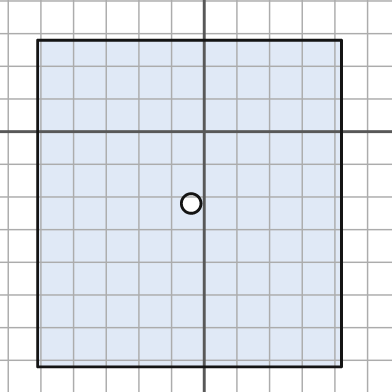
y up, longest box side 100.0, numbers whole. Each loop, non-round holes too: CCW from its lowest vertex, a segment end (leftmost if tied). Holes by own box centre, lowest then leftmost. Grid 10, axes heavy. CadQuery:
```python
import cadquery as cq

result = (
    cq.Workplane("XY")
    .moveTo(-51.0, -72.0)
    .lineTo(42.0, -72.0)
    .lineTo(42.0, 28.0)
    .lineTo(-51.0, 28.0)
    .close()
    .moveTo(-4.0, -22.0)
    .circle(3.0)
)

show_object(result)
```